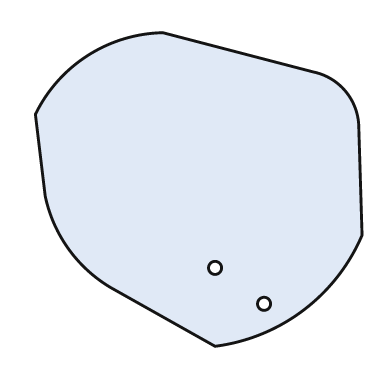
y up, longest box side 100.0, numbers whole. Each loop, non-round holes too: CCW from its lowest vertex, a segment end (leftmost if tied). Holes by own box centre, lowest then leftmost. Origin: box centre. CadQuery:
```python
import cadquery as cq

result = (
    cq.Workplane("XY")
    .moveTo(5.0, -48.0)
    .threePointArc((32.0, -37.0), (50.0, -14.0))
    .lineTo(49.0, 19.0)
    .threePointArc((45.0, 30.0), (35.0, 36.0))
    .lineTo(-11.0, 48.0)
    .threePointArc((-34.0, 41.0), (-50.0, 23.0))
    .lineTo(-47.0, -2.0)
    .threePointArc((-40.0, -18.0), (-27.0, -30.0))
    .close()
    .moveTo(20.0, -35.0)
    .circle(2.0)
    .moveTo(5.0, -24.0)
    .circle(2.0)
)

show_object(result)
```